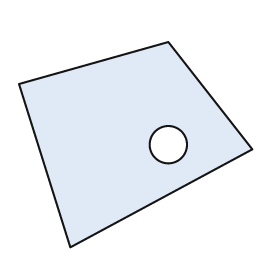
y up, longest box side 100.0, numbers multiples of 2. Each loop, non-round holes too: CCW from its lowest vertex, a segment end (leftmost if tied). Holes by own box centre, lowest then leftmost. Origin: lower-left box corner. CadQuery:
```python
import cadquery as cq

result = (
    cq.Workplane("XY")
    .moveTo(22.0, 0.0)
    .lineTo(100.0, 42.0)
    .lineTo(64.0, 88.0)
    .lineTo(0.0, 70.0)
    .close()
    .moveTo(64.0, 44.0)
    .circle(8.0)
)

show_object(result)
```